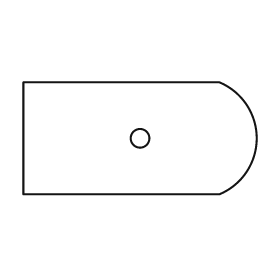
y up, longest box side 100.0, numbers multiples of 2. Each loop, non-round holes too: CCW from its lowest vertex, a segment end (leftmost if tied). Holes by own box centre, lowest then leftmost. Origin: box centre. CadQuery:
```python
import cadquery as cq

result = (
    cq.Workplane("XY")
    .moveTo(-50.0, -24.0)
    .lineTo(34.0, -24.0)
    .threePointArc((50.0, 0.0), (34.0, 24.0))
    .lineTo(-50.0, 24.0)
    .close()
    .moveTo(0.0, 0.0)
    .circle(4.0)
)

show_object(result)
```